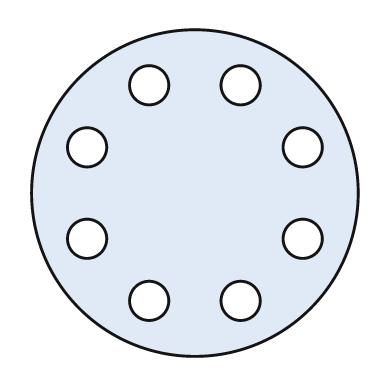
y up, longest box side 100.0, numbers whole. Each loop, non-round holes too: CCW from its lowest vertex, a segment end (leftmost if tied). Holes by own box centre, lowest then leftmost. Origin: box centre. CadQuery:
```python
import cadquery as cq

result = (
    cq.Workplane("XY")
    .moveTo(0.0, 0.0)
    .circle(50.0)
    .moveTo(-14.0, -33.0)
    .circle(6.0)
    .moveTo(14.0, -33.0)
    .circle(6.0)
    .moveTo(-33.0, -14.0)
    .circle(6.0)
    .moveTo(33.0, -14.0)
    .circle(6.0)
    .moveTo(-33.0, 14.0)
    .circle(6.0)
    .moveTo(33.0, 14.0)
    .circle(6.0)
    .moveTo(-14.0, 33.0)
    .circle(6.0)
    .moveTo(14.0, 33.0)
    .circle(6.0)
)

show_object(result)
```